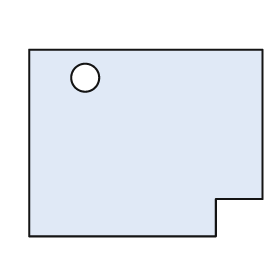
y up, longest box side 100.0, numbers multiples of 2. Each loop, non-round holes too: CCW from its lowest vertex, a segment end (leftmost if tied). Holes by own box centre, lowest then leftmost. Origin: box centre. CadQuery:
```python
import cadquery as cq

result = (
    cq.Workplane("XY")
    .moveTo(-50.0, -40.0)
    .lineTo(30.0, -40.0)
    .lineTo(30.0, -24.0)
    .lineTo(50.0, -24.0)
    .lineTo(50.0, 40.0)
    .lineTo(-50.0, 40.0)
    .close()
    .moveTo(-26.0, 28.0)
    .circle(6.0)
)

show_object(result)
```